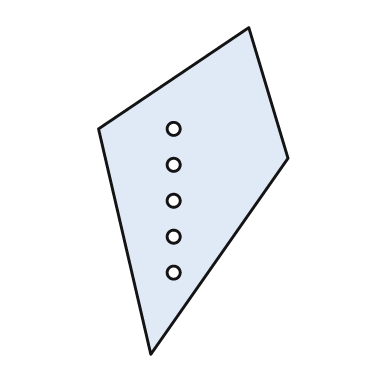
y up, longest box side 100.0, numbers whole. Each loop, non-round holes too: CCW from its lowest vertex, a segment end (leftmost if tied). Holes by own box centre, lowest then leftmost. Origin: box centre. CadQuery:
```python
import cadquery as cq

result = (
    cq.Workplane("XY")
    .moveTo(-13.0, -50.0)
    .lineTo(29.0, 10.0)
    .lineTo(17.0, 50.0)
    .lineTo(-29.0, 19.0)
    .close()
    .moveTo(-6.0, -25.0)
    .circle(2.0)
    .moveTo(-6.0, -14.0)
    .circle(2.0)
    .moveTo(-6.0, -3.0)
    .circle(2.0)
    .moveTo(-6.0, 8.0)
    .circle(2.0)
    .moveTo(-6.0, 19.0)
    .circle(2.0)
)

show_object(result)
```